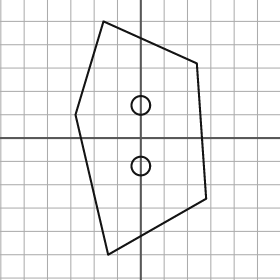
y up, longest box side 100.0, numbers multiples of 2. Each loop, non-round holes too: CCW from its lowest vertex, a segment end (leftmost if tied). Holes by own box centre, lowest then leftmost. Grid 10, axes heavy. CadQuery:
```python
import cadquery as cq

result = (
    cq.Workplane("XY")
    .moveTo(-14.0, -50.0)
    .lineTo(28.0, -26.0)
    .lineTo(24.0, 32.0)
    .lineTo(-16.0, 50.0)
    .lineTo(-28.0, 10.0)
    .close()
    .moveTo(0.0, -12.0)
    .circle(4.0)
    .moveTo(0.0, 14.0)
    .circle(4.0)
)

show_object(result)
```